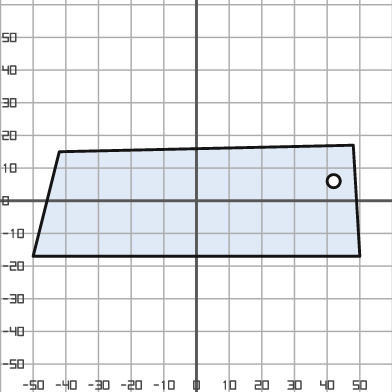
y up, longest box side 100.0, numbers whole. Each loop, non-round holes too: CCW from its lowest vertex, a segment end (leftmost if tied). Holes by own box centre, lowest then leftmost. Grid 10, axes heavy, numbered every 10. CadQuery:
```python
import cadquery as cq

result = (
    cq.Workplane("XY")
    .moveTo(-50.0, -17.0)
    .lineTo(50.0, -17.0)
    .lineTo(48.0, 17.0)
    .lineTo(-42.0, 15.0)
    .close()
    .moveTo(42.0, 6.0)
    .circle(2.0)
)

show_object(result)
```